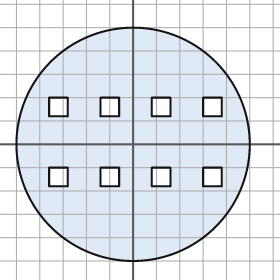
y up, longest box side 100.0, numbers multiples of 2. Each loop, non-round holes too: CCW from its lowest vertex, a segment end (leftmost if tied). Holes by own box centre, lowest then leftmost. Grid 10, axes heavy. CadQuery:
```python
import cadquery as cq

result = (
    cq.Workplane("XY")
    .moveTo(0.0, 0.0)
    .circle(50.0)
    .moveTo(-36.0, -18.0)
    .lineTo(-28.0, -18.0)
    .lineTo(-28.0, -10.0)
    .lineTo(-36.0, -10.0)
    .close()
    .moveTo(-14.0, -18.0)
    .lineTo(-6.0, -18.0)
    .lineTo(-6.0, -10.0)
    .lineTo(-14.0, -10.0)
    .close()
    .moveTo(8.0, -18.0)
    .lineTo(16.0, -18.0)
    .lineTo(16.0, -10.0)
    .lineTo(8.0, -10.0)
    .close()
    .moveTo(30.0, -18.0)
    .lineTo(38.0, -18.0)
    .lineTo(38.0, -10.0)
    .lineTo(30.0, -10.0)
    .close()
    .moveTo(-36.0, 12.0)
    .lineTo(-28.0, 12.0)
    .lineTo(-28.0, 20.0)
    .lineTo(-36.0, 20.0)
    .close()
    .moveTo(-14.0, 12.0)
    .lineTo(-6.0, 12.0)
    .lineTo(-6.0, 20.0)
    .lineTo(-14.0, 20.0)
    .close()
    .moveTo(8.0, 12.0)
    .lineTo(16.0, 12.0)
    .lineTo(16.0, 20.0)
    .lineTo(8.0, 20.0)
    .close()
    .moveTo(30.0, 12.0)
    .lineTo(38.0, 12.0)
    .lineTo(38.0, 20.0)
    .lineTo(30.0, 20.0)
    .close()
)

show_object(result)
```